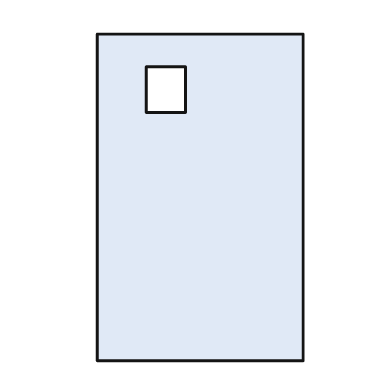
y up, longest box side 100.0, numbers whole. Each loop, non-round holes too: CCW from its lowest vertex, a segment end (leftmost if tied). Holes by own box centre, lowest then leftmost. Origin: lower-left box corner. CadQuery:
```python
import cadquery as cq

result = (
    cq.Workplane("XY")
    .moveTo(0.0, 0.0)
    .lineTo(63.0, 0.0)
    .lineTo(63.0, 100.0)
    .lineTo(0.0, 100.0)
    .close()
    .moveTo(15.0, 76.0)
    .lineTo(27.0, 76.0)
    .lineTo(27.0, 90.0)
    .lineTo(15.0, 90.0)
    .close()
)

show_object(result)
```